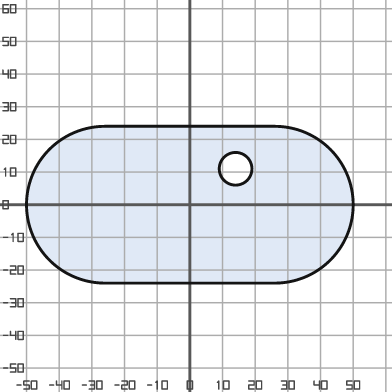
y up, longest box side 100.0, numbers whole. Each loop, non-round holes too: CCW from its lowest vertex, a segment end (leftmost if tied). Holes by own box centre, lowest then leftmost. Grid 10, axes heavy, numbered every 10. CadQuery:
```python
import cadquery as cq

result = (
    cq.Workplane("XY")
    .moveTo(-26.0, -24.0)
    .lineTo(26.0, -24.0)
    .threePointArc((50.0, 0.0), (26.0, 24.0))
    .lineTo(-26.0, 24.0)
    .threePointArc((-50.0, 0.0), (-26.0, -24.0))
    .close()
    .moveTo(14.0, 11.0)
    .circle(5.0)
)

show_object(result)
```